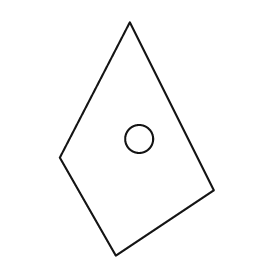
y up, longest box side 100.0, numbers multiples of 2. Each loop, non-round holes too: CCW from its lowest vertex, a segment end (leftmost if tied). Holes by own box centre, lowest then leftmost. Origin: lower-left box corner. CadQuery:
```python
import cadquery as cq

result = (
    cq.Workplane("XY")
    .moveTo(24.0, 0.0)
    .lineTo(66.0, 28.0)
    .lineTo(30.0, 100.0)
    .lineTo(0.0, 42.0)
    .close()
    .moveTo(34.0, 50.0)
    .circle(6.0)
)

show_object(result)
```